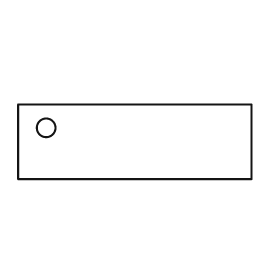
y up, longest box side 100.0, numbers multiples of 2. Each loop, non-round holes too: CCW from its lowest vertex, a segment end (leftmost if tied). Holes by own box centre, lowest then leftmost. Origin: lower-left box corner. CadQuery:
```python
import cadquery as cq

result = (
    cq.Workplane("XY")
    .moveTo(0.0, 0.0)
    .lineTo(100.0, 0.0)
    .lineTo(100.0, 32.0)
    .lineTo(0.0, 32.0)
    .close()
    .moveTo(12.0, 22.0)
    .circle(4.0)
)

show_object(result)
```